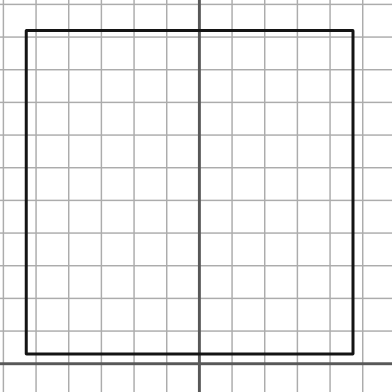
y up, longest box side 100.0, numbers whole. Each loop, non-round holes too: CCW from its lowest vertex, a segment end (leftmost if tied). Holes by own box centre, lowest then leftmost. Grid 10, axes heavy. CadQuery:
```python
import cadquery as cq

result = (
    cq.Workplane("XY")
    .moveTo(-53.0, 3.0)
    .lineTo(47.0, 3.0)
    .lineTo(47.0, 102.0)
    .lineTo(-53.0, 102.0)
    .close()
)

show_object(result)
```